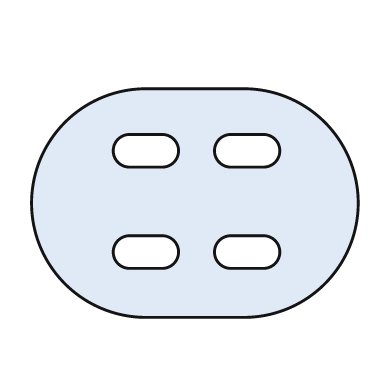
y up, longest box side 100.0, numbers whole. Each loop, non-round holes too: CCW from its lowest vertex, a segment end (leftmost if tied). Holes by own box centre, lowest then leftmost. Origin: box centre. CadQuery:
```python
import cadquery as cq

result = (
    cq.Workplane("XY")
    .moveTo(-15.0, -35.0)
    .lineTo(15.0, -35.0)
    .threePointArc((50.0, 0.0), (15.0, 35.0))
    .lineTo(-15.0, 35.0)
    .threePointArc((-50.0, 0.0), (-15.0, -35.0))
    .close()
    .moveTo(-20.0, -20.0)
    .lineTo(-10.0, -20.0)
    .threePointArc((-5.0, -15.0), (-10.0, -10.0))
    .lineTo(-20.0, -10.0)
    .threePointArc((-25.0, -15.0), (-20.0, -20.0))
    .close()
    .moveTo(11.0, -20.0)
    .lineTo(21.0, -20.0)
    .threePointArc((26.0, -15.0), (21.0, -10.0))
    .lineTo(11.0, -10.0)
    .threePointArc((6.0, -15.0), (11.0, -20.0))
    .close()
    .moveTo(-20.0, 11.0)
    .lineTo(-10.0, 11.0)
    .threePointArc((-5.0, 16.0), (-10.0, 21.0))
    .lineTo(-20.0, 21.0)
    .threePointArc((-25.0, 16.0), (-20.0, 11.0))
    .close()
    .moveTo(11.0, 11.0)
    .lineTo(21.0, 11.0)
    .threePointArc((26.0, 16.0), (21.0, 21.0))
    .lineTo(11.0, 21.0)
    .threePointArc((6.0, 16.0), (11.0, 11.0))
    .close()
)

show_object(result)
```